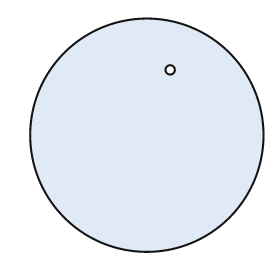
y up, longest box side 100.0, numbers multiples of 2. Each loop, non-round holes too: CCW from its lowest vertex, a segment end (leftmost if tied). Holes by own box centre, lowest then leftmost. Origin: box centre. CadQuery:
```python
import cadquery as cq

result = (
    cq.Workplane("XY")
    .moveTo(0.0, 0.0)
    .circle(50.0)
    .moveTo(10.0, 28.0)
    .circle(2.0)
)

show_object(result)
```